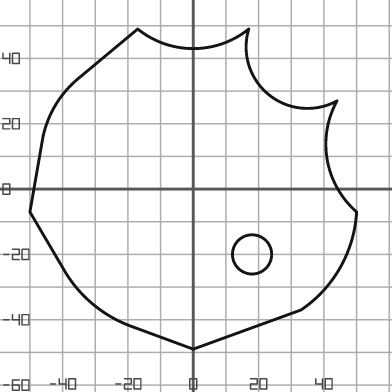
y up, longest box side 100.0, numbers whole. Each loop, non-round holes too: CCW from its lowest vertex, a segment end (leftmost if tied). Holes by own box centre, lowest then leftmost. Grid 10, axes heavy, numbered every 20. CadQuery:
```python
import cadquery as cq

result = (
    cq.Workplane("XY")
    .moveTo(0.0, -49.0)
    .lineTo(33.0, -37.0)
    .threePointArc((45.0, -24.0), (50.0, -7.0))
    .threePointArc((41.0, 9.0), (44.0, 27.0))
    .threePointArc((23.0, 29.0), (17.0, 49.0))
    .threePointArc((0.0, 43.0), (-17.0, 49.0))
    .lineTo(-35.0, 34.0)
    .threePointArc((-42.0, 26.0), (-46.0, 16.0))
    .lineTo(-50.0, -7.0)
    .lineTo(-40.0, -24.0)
    .threePointArc((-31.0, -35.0), (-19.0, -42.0))
    .close()
    .moveTo(18.0, -20.0)
    .circle(6.0)
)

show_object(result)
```